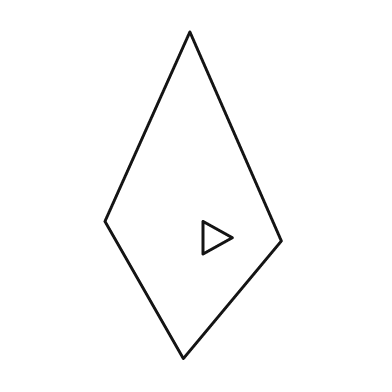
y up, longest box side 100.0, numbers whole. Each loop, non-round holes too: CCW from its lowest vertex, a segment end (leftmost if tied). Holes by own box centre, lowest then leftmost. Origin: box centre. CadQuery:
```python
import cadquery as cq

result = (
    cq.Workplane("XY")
    .moveTo(-3.0, -50.0)
    .lineTo(27.0, -14.0)
    .lineTo(-1.0, 50.0)
    .lineTo(-27.0, -8.0)
    .close()
    .moveTo(3.0, -18.0)
    .lineTo(12.0, -13.0)
    .lineTo(3.0, -8.0)
    .close()
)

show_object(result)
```